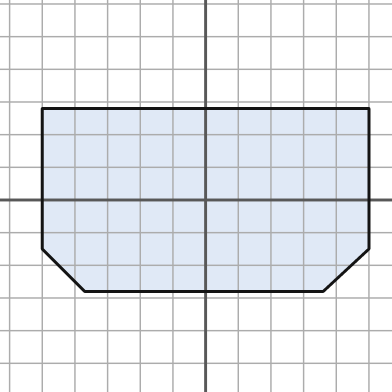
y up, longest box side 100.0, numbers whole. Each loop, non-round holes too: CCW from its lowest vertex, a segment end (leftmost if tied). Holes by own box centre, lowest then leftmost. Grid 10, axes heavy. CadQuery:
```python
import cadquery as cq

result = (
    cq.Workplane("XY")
    .moveTo(-37.0, -28.0)
    .lineTo(36.0, -28.0)
    .lineTo(50.0, -15.0)
    .lineTo(50.0, 28.0)
    .lineTo(-50.0, 28.0)
    .lineTo(-50.0, -15.0)
    .close()
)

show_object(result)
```